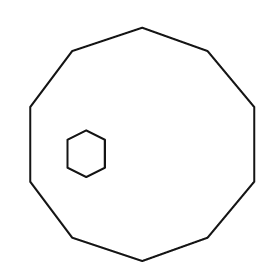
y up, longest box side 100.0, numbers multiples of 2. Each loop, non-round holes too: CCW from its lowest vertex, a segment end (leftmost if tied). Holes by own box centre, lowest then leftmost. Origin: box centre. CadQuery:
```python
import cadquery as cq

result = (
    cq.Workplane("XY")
    .moveTo(0.0, -50.0)
    .lineTo(28.0, -40.0)
    .lineTo(48.0, -16.0)
    .lineTo(48.0, 16.0)
    .lineTo(28.0, 40.0)
    .lineTo(0.0, 50.0)
    .lineTo(-30.0, 40.0)
    .lineTo(-48.0, 16.0)
    .lineTo(-48.0, -16.0)
    .lineTo(-30.0, -40.0)
    .close()
    .moveTo(-24.0, -14.0)
    .lineTo(-16.0, -10.0)
    .lineTo(-16.0, 2.0)
    .lineTo(-24.0, 6.0)
    .lineTo(-32.0, 2.0)
    .lineTo(-32.0, -10.0)
    .close()
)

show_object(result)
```